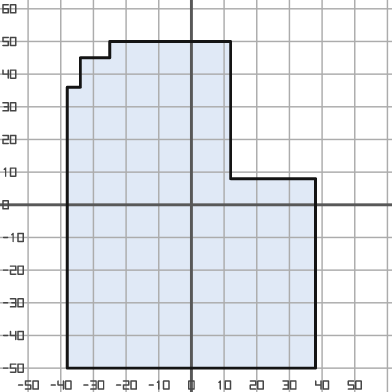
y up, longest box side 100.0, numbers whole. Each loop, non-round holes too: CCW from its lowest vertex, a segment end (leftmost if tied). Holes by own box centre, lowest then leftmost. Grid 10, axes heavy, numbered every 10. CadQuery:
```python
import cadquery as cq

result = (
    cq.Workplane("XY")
    .moveTo(-38.0, -50.0)
    .lineTo(38.0, -50.0)
    .lineTo(38.0, 8.0)
    .lineTo(12.0, 8.0)
    .lineTo(12.0, 50.0)
    .lineTo(-25.0, 50.0)
    .lineTo(-25.0, 45.0)
    .lineTo(-34.0, 45.0)
    .lineTo(-34.0, 36.0)
    .lineTo(-38.0, 36.0)
    .close()
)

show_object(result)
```